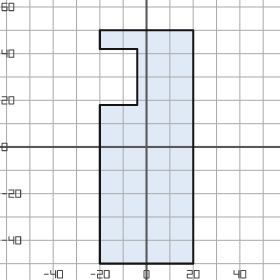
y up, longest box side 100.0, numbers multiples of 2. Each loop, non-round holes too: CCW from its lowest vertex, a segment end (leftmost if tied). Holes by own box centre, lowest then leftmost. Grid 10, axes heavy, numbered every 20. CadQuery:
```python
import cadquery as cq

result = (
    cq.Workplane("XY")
    .moveTo(-20.0, -50.0)
    .lineTo(20.0, -50.0)
    .lineTo(20.0, 50.0)
    .lineTo(-20.0, 50.0)
    .lineTo(-20.0, 42.0)
    .lineTo(-4.0, 42.0)
    .lineTo(-4.0, 18.0)
    .lineTo(-20.0, 18.0)
    .close()
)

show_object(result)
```